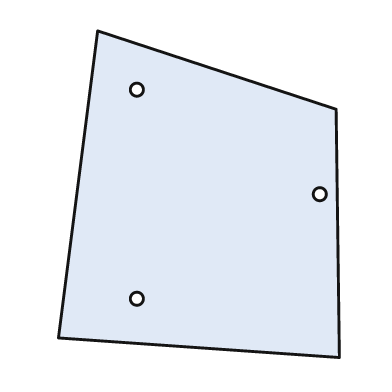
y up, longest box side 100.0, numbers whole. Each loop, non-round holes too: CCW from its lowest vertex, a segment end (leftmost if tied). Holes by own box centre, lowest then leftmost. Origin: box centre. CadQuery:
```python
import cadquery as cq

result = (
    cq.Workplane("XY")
    .moveTo(43.0, -50.0)
    .lineTo(42.0, 26.0)
    .lineTo(-31.0, 50.0)
    .lineTo(-43.0, -44.0)
    .close()
    .moveTo(-19.0, -32.0)
    .circle(2.0)
    .moveTo(37.0, 0.0)
    .circle(2.0)
    .moveTo(-19.0, 32.0)
    .circle(2.0)
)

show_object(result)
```